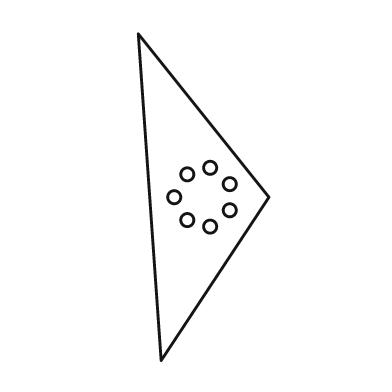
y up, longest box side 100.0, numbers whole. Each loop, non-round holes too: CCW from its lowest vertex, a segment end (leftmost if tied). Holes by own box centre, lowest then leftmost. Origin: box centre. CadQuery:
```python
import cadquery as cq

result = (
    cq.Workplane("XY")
    .moveTo(-13.0, -50.0)
    .lineTo(20.0, 0.0)
    .lineTo(-20.0, 50.0)
    .close()
    .moveTo(2.0, -9.0)
    .circle(2.0)
    .moveTo(-5.0, -7.0)
    .circle(2.0)
    .moveTo(8.0, -4.0)
    .circle(2.0)
    .moveTo(-9.0, 0.0)
    .circle(2.0)
    .moveTo(8.0, 4.0)
    .circle(2.0)
    .moveTo(-5.0, 7.0)
    .circle(2.0)
    .moveTo(2.0, 9.0)
    .circle(2.0)
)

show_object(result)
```